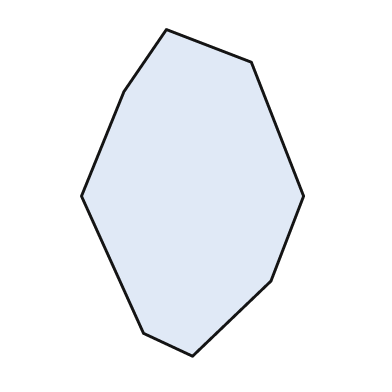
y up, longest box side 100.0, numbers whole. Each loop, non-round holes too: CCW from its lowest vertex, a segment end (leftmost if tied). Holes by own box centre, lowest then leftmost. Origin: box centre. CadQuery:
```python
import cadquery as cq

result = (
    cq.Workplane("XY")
    .moveTo(0.0, -50.0)
    .lineTo(24.0, -27.0)
    .lineTo(34.0, -1.0)
    .lineTo(18.0, 40.0)
    .lineTo(-8.0, 50.0)
    .lineTo(-21.0, 31.0)
    .lineTo(-34.0, -1.0)
    .lineTo(-15.0, -43.0)
    .close()
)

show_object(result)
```